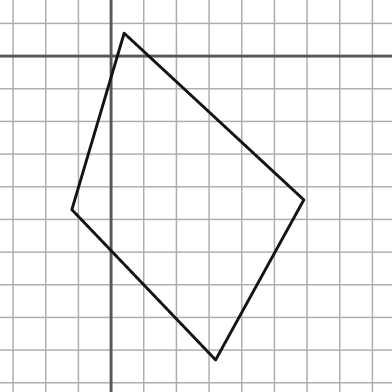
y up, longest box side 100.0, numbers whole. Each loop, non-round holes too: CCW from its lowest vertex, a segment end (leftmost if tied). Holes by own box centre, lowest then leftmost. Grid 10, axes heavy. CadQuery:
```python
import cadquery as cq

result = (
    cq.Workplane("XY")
    .moveTo(32.0, -93.0)
    .lineTo(59.0, -44.0)
    .lineTo(4.0, 7.0)
    .lineTo(-12.0, -47.0)
    .close()
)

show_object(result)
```